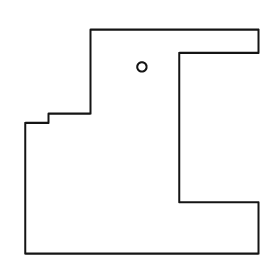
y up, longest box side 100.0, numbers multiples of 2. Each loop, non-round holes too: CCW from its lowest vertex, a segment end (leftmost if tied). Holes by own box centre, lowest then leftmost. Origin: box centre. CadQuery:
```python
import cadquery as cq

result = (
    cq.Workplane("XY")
    .moveTo(-50.0, -48.0)
    .lineTo(50.0, -48.0)
    .lineTo(50.0, -26.0)
    .lineTo(16.0, -26.0)
    .lineTo(16.0, 38.0)
    .lineTo(50.0, 38.0)
    .lineTo(50.0, 48.0)
    .lineTo(-22.0, 48.0)
    .lineTo(-22.0, 12.0)
    .lineTo(-40.0, 12.0)
    .lineTo(-40.0, 8.0)
    .lineTo(-50.0, 8.0)
    .close()
    .moveTo(0.0, 32.0)
    .circle(2.0)
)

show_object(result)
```